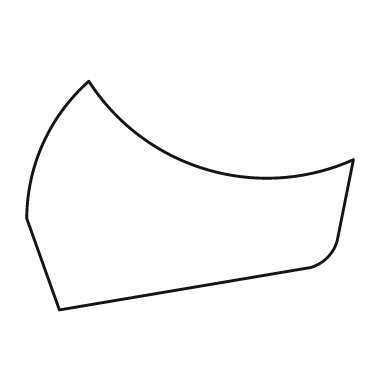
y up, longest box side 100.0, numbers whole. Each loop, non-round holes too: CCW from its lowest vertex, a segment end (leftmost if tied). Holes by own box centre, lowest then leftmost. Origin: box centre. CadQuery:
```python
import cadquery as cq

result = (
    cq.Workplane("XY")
    .moveTo(-40.0, -35.0)
    .lineTo(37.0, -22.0)
    .threePointArc((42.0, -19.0), (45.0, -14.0))
    .lineTo(50.0, 11.0)
    .threePointArc((5.0, 8.0), (-31.0, 35.0))
    .threePointArc((-45.0, 16.0), (-50.0, -7.0))
    .close()
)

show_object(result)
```